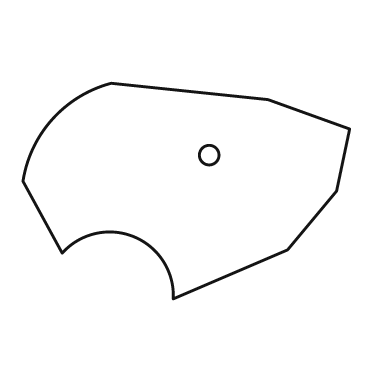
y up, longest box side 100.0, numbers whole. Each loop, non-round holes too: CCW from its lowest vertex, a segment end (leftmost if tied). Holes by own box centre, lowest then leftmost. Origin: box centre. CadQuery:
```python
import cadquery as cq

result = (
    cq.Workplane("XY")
    .moveTo(-4.0, -33.0)
    .lineTo(31.0, -18.0)
    .lineTo(46.0, 0.0)
    .lineTo(50.0, 19.0)
    .lineTo(25.0, 28.0)
    .lineTo(-23.0, 33.0)
    .threePointArc((-41.0, 22.0), (-50.0, 3.0))
    .lineTo(-38.0, -19.0)
    .threePointArc((-16.0, -14.0), (-4.0, -33.0))
    .close()
    .moveTo(7.0, 11.0)
    .circle(3.0)
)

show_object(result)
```